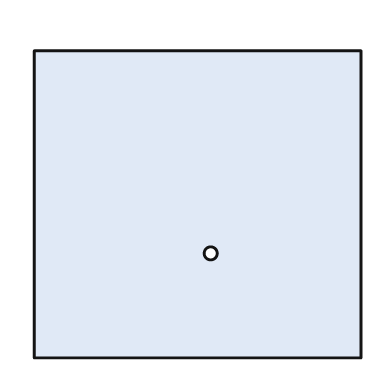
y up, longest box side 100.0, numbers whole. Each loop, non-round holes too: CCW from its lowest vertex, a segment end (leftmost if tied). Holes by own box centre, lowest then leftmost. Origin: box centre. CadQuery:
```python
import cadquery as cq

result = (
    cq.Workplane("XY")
    .moveTo(-50.0, -47.0)
    .lineTo(50.0, -47.0)
    .lineTo(50.0, 47.0)
    .lineTo(-50.0, 47.0)
    .close()
    .moveTo(4.0, -15.0)
    .circle(2.0)
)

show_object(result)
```